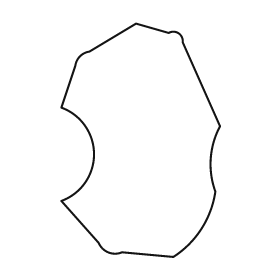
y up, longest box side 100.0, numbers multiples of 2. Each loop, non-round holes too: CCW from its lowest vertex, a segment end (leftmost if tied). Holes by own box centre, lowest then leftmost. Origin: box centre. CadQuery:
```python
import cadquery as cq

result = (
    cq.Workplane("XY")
    .moveTo(14.0, -50.0)
    .threePointArc((26.0, -38.0), (32.0, -22.0))
    .threePointArc((30.0, -8.0), (34.0, 6.0))
    .lineTo(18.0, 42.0)
    .threePointArc((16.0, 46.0), (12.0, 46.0))
    .lineTo(-2.0, 50.0)
    .lineTo(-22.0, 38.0)
    .threePointArc((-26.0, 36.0), (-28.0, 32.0))
    .lineTo(-34.0, 14.0)
    .threePointArc((-20.0, -6.0), (-34.0, -26.0))
    .lineTo(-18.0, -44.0)
    .threePointArc((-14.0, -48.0), (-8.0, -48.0))
    .close()
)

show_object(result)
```